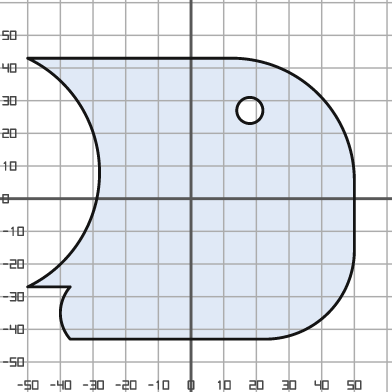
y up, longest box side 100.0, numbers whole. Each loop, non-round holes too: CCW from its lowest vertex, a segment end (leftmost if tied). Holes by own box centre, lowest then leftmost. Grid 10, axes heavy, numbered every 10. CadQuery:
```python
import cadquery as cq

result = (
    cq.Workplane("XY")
    .moveTo(-37.0, -43.0)
    .lineTo(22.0, -43.0)
    .threePointArc((42.0, -35.0), (50.0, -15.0))
    .lineTo(50.0, 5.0)
    .threePointArc((39.0, 32.0), (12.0, 43.0))
    .lineTo(-50.0, 43.0)
    .threePointArc((-28.0, 8.0), (-50.0, -27.0))
    .lineTo(-37.0, -27.0)
    .threePointArc((-40.0, -35.0), (-37.0, -43.0))
    .close()
    .moveTo(18.0, 27.0)
    .circle(4.0)
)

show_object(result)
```